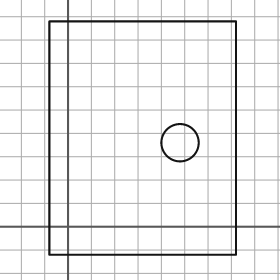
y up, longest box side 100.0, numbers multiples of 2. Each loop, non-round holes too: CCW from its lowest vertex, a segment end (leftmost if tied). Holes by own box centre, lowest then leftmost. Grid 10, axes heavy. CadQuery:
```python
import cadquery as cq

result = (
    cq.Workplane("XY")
    .moveTo(-8.0, -12.0)
    .lineTo(72.0, -12.0)
    .lineTo(72.0, 88.0)
    .lineTo(-8.0, 88.0)
    .close()
    .moveTo(48.0, 36.0)
    .circle(8.0)
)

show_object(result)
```